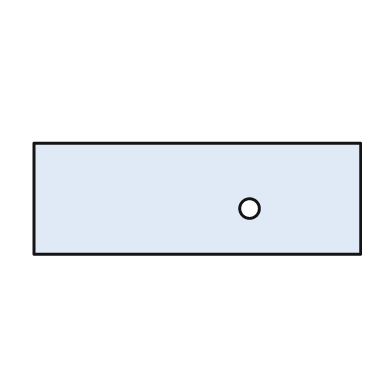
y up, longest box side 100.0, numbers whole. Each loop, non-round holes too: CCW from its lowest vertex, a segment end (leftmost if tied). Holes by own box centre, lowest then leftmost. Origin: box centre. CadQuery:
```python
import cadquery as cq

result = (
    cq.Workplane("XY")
    .moveTo(-50.0, -17.0)
    .lineTo(50.0, -17.0)
    .lineTo(50.0, 17.0)
    .lineTo(-50.0, 17.0)
    .close()
    .moveTo(16.0, -3.0)
    .circle(3.0)
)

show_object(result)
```